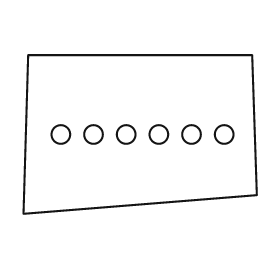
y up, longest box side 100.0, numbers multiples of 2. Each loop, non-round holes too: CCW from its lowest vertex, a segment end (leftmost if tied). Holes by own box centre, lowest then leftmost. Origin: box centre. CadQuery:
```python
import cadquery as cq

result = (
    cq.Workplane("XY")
    .moveTo(-50.0, -34.0)
    .lineTo(50.0, -26.0)
    .lineTo(48.0, 34.0)
    .lineTo(-48.0, 34.0)
    .close()
    .moveTo(-34.0, 0.0)
    .circle(4.0)
    .moveTo(-20.0, 0.0)
    .circle(4.0)
    .moveTo(-6.0, 0.0)
    .circle(4.0)
    .moveTo(8.0, 0.0)
    .circle(4.0)
    .moveTo(22.0, 0.0)
    .circle(4.0)
    .moveTo(36.0, 0.0)
    .circle(4.0)
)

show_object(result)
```